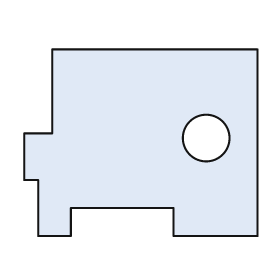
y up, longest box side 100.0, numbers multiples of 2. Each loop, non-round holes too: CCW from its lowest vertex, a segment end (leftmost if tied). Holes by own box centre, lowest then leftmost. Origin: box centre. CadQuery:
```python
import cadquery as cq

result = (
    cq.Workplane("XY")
    .moveTo(-44.0, -40.0)
    .lineTo(-30.0, -40.0)
    .lineTo(-30.0, -28.0)
    .lineTo(14.0, -28.0)
    .lineTo(14.0, -40.0)
    .lineTo(50.0, -40.0)
    .lineTo(50.0, 40.0)
    .lineTo(-38.0, 40.0)
    .lineTo(-38.0, 4.0)
    .lineTo(-50.0, 4.0)
    .lineTo(-50.0, -16.0)
    .lineTo(-44.0, -16.0)
    .close()
    .moveTo(28.0, 2.0)
    .circle(10.0)
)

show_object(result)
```